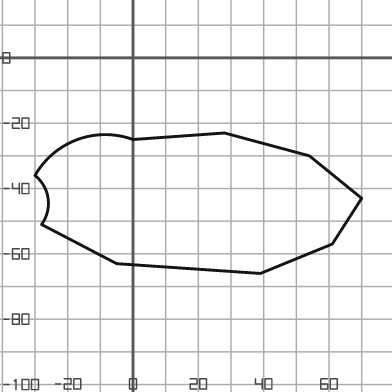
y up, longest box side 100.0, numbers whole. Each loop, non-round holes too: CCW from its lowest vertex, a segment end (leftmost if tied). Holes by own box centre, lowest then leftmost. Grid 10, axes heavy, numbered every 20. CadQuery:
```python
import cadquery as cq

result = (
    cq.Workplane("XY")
    .moveTo(39.0, -66.0)
    .lineTo(61.0, -57.0)
    .lineTo(70.0, -43.0)
    .lineTo(54.0, -30.0)
    .lineTo(28.0, -23.0)
    .lineTo(0.0, -25.0)
    .threePointArc((-17.0, -25.0), (-30.0, -36.0))
    .threePointArc((-26.0, -43.0), (-28.0, -51.0))
    .lineTo(-5.0, -63.0)
    .close()
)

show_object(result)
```